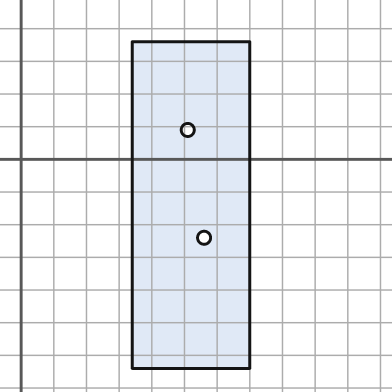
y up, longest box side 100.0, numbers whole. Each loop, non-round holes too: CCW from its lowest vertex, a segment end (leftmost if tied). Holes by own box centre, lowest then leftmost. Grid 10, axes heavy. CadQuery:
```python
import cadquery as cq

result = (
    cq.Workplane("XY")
    .moveTo(34.0, -64.0)
    .lineTo(70.0, -64.0)
    .lineTo(70.0, 36.0)
    .lineTo(34.0, 36.0)
    .close()
    .moveTo(56.0, -24.0)
    .circle(2.0)
    .moveTo(51.0, 9.0)
    .circle(2.0)
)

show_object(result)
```